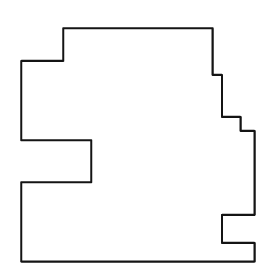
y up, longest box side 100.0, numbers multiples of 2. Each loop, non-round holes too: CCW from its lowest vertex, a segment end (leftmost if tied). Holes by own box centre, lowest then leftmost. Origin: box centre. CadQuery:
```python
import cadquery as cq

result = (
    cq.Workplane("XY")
    .moveTo(-50.0, -50.0)
    .lineTo(50.0, -50.0)
    .lineTo(50.0, -42.0)
    .lineTo(36.0, -42.0)
    .lineTo(36.0, -30.0)
    .lineTo(50.0, -30.0)
    .lineTo(50.0, 6.0)
    .lineTo(44.0, 6.0)
    .lineTo(44.0, 12.0)
    .lineTo(36.0, 12.0)
    .lineTo(36.0, 30.0)
    .lineTo(32.0, 30.0)
    .lineTo(32.0, 50.0)
    .lineTo(-32.0, 50.0)
    .lineTo(-32.0, 36.0)
    .lineTo(-50.0, 36.0)
    .lineTo(-50.0, 2.0)
    .lineTo(-20.0, 2.0)
    .lineTo(-20.0, -16.0)
    .lineTo(-50.0, -16.0)
    .close()
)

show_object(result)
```